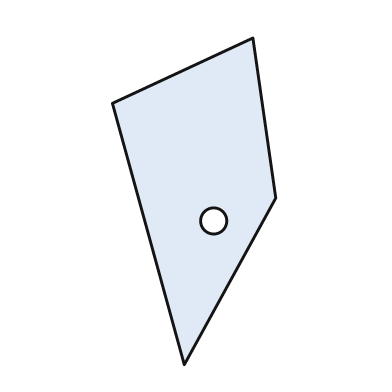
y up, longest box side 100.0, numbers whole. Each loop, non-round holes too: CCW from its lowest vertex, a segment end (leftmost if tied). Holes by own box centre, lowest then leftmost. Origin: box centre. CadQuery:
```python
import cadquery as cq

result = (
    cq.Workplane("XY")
    .moveTo(-3.0, -50.0)
    .lineTo(25.0, 1.0)
    .lineTo(18.0, 50.0)
    .lineTo(-25.0, 30.0)
    .close()
    .moveTo(6.0, -6.0)
    .circle(4.0)
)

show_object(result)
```